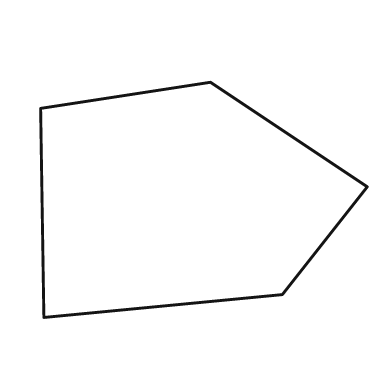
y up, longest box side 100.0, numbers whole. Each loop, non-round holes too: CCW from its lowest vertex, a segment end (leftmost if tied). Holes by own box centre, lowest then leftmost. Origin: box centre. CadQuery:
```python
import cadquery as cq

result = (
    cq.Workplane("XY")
    .moveTo(-49.0, -36.0)
    .lineTo(24.0, -29.0)
    .lineTo(50.0, 4.0)
    .lineTo(2.0, 36.0)
    .lineTo(-50.0, 28.0)
    .close()
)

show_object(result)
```